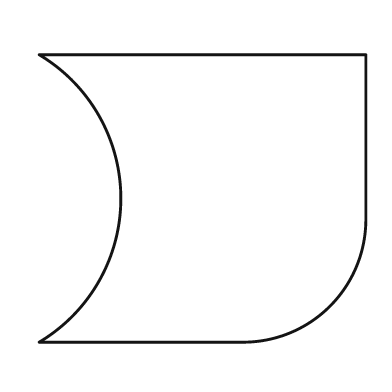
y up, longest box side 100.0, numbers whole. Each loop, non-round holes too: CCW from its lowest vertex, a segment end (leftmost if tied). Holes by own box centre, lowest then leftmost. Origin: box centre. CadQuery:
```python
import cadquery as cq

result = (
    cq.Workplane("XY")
    .moveTo(-50.0, -44.0)
    .lineTo(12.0, -44.0)
    .threePointArc((39.0, -33.0), (50.0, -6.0))
    .lineTo(50.0, 44.0)
    .lineTo(-50.0, 44.0)
    .threePointArc((-25.0, 0.0), (-50.0, -44.0))
    .close()
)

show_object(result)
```